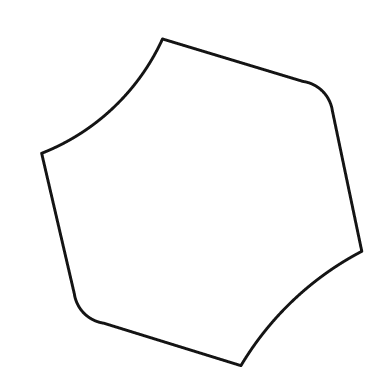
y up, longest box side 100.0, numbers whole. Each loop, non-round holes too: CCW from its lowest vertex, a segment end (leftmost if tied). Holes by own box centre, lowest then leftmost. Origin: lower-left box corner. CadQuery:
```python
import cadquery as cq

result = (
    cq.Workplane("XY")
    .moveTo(61.0, 0.0)
    .threePointArc((77.0, 20.0), (98.0, 35.0))
    .lineTo(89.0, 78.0)
    .threePointArc((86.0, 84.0), (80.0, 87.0))
    .lineTo(37.0, 100.0)
    .threePointArc((22.0, 79.0), (0.0, 65.0))
    .lineTo(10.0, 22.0)
    .threePointArc((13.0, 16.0), (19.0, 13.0))
    .close()
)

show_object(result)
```